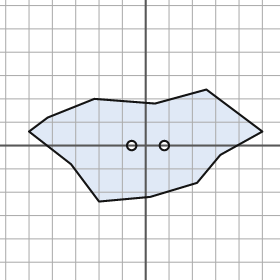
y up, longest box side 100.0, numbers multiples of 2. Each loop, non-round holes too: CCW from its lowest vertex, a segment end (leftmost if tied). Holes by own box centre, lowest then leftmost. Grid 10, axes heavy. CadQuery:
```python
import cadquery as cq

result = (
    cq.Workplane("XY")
    .moveTo(-20.0, -24.0)
    .lineTo(2.0, -22.0)
    .lineTo(22.0, -16.0)
    .lineTo(32.0, -4.0)
    .lineTo(50.0, 6.0)
    .lineTo(26.0, 24.0)
    .lineTo(4.0, 18.0)
    .lineTo(-22.0, 20.0)
    .lineTo(-42.0, 12.0)
    .lineTo(-50.0, 6.0)
    .lineTo(-32.0, -8.0)
    .close()
    .moveTo(-6.0, 0.0)
    .circle(2.0)
    .moveTo(8.0, 0.0)
    .circle(2.0)
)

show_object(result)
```